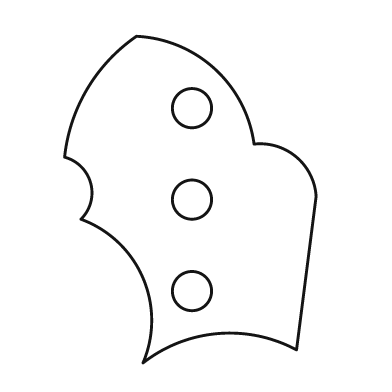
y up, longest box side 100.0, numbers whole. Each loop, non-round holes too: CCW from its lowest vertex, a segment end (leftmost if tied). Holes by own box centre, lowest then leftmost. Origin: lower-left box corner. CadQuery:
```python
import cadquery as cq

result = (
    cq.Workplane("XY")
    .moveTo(24.0, 0.0)
    .threePointArc((47.0, 9.0), (71.0, 4.0))
    .lineTo(77.0, 51.0)
    .threePointArc((71.0, 63.0), (58.0, 67.0))
    .threePointArc((46.0, 90.0), (22.0, 100.0))
    .threePointArc((7.0, 84.0), (0.0, 63.0))
    .threePointArc((8.0, 55.0), (5.0, 44.0))
    .threePointArc((24.0, 26.0), (24.0, 0.0))
    .close()
    .moveTo(39.0, 22.0)
    .circle(6.0)
    .moveTo(39.0, 50.0)
    .circle(6.0)
    .moveTo(39.0, 78.0)
    .circle(6.0)
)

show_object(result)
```